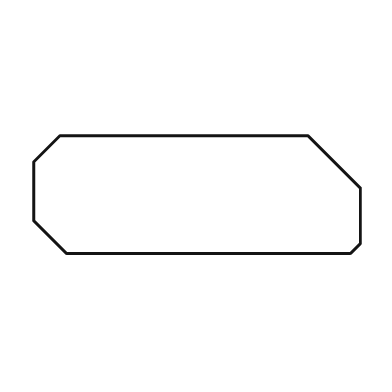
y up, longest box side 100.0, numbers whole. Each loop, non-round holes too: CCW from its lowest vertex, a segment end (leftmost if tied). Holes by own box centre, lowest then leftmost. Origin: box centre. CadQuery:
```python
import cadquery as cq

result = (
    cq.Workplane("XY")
    .moveTo(-40.0, -18.0)
    .lineTo(47.0, -18.0)
    .lineTo(50.0, -15.0)
    .lineTo(50.0, 2.0)
    .lineTo(34.0, 18.0)
    .lineTo(-42.0, 18.0)
    .lineTo(-50.0, 10.0)
    .lineTo(-50.0, -8.0)
    .close()
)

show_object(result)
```